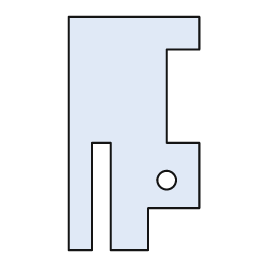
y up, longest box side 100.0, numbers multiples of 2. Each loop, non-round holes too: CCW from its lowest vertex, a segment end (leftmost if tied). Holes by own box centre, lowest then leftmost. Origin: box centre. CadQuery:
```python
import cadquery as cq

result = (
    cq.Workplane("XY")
    .moveTo(-28.0, -50.0)
    .lineTo(-18.0, -50.0)
    .lineTo(-18.0, -4.0)
    .lineTo(-10.0, -4.0)
    .lineTo(-10.0, -50.0)
    .lineTo(6.0, -50.0)
    .lineTo(6.0, -32.0)
    .lineTo(28.0, -32.0)
    .lineTo(28.0, -4.0)
    .lineTo(14.0, -4.0)
    .lineTo(14.0, 36.0)
    .lineTo(28.0, 36.0)
    .lineTo(28.0, 50.0)
    .lineTo(-28.0, 50.0)
    .close()
    .moveTo(14.0, -20.0)
    .circle(4.0)
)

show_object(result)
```